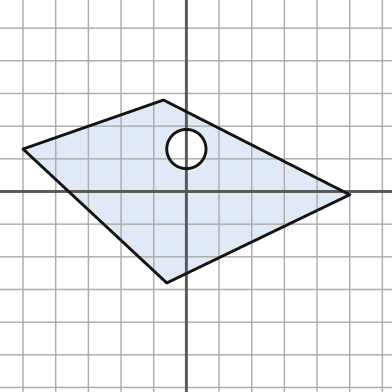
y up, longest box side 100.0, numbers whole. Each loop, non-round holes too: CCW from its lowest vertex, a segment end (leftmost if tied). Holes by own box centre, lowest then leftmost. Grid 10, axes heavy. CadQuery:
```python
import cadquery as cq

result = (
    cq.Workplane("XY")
    .moveTo(-6.0, -28.0)
    .lineTo(50.0, -1.0)
    .lineTo(-7.0, 28.0)
    .lineTo(-50.0, 13.0)
    .close()
    .moveTo(0.0, 13.0)
    .circle(6.0)
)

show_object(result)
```